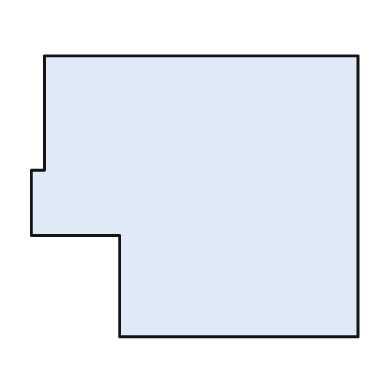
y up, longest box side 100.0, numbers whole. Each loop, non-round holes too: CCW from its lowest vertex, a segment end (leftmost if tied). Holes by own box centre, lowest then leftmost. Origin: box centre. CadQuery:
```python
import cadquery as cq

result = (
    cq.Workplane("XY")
    .moveTo(-23.0, -43.0)
    .lineTo(50.0, -43.0)
    .lineTo(50.0, 43.0)
    .lineTo(-46.0, 43.0)
    .lineTo(-46.0, 8.0)
    .lineTo(-50.0, 8.0)
    .lineTo(-50.0, -12.0)
    .lineTo(-23.0, -12.0)
    .close()
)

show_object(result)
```